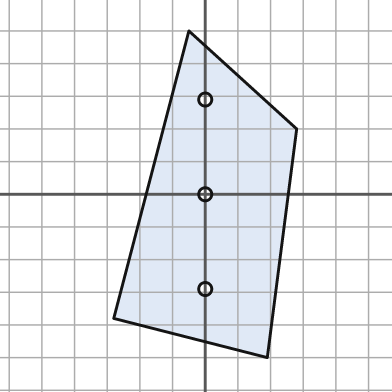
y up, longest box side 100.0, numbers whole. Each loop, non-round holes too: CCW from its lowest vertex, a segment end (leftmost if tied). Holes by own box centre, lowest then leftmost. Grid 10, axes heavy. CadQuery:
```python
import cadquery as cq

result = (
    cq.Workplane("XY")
    .moveTo(19.0, -50.0)
    .lineTo(28.0, 20.0)
    .lineTo(-5.0, 50.0)
    .lineTo(-28.0, -38.0)
    .close()
    .moveTo(0.0, -29.0)
    .circle(2.0)
    .moveTo(0.0, 0.0)
    .circle(2.0)
    .moveTo(0.0, 29.0)
    .circle(2.0)
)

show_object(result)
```